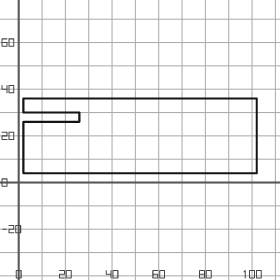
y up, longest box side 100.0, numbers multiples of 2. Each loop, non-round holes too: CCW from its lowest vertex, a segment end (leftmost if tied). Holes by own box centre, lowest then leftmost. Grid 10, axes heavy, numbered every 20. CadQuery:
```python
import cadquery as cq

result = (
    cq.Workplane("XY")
    .moveTo(2.0, 4.0)
    .lineTo(102.0, 4.0)
    .lineTo(102.0, 36.0)
    .lineTo(2.0, 36.0)
    .lineTo(2.0, 30.0)
    .lineTo(26.0, 30.0)
    .lineTo(26.0, 26.0)
    .lineTo(2.0, 26.0)
    .close()
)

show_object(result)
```